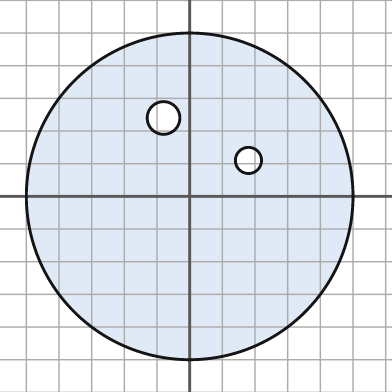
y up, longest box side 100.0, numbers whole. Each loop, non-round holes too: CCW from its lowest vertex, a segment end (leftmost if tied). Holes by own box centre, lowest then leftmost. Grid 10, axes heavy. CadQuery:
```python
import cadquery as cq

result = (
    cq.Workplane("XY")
    .moveTo(0.0, 0.0)
    .circle(50.0)
    .moveTo(18.0, 11.0)
    .circle(4.0)
    .moveTo(-8.0, 24.0)
    .circle(5.0)
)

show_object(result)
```